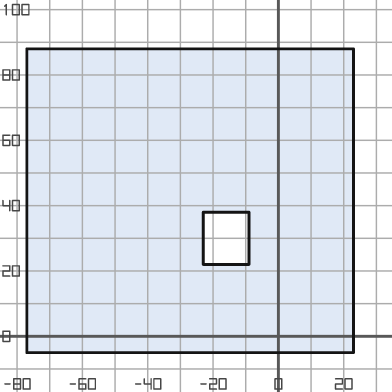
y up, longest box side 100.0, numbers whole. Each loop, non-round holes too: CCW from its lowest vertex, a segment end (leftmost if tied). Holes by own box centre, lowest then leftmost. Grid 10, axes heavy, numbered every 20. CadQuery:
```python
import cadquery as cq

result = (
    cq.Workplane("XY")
    .moveTo(-77.0, -5.0)
    .lineTo(23.0, -5.0)
    .lineTo(23.0, 88.0)
    .lineTo(-77.0, 88.0)
    .close()
    .moveTo(-23.0, 22.0)
    .lineTo(-9.0, 22.0)
    .lineTo(-9.0, 38.0)
    .lineTo(-23.0, 38.0)
    .close()
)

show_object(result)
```